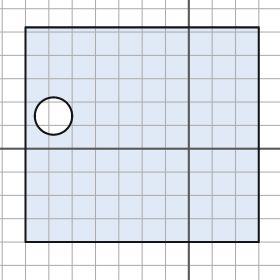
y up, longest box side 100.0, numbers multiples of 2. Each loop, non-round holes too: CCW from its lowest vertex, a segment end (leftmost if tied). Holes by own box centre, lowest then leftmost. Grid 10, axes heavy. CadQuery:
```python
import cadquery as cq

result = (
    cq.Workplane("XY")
    .moveTo(-70.0, -40.0)
    .lineTo(30.0, -40.0)
    .lineTo(30.0, 52.0)
    .lineTo(-70.0, 52.0)
    .close()
    .moveTo(-58.0, 14.0)
    .circle(8.0)
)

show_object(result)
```